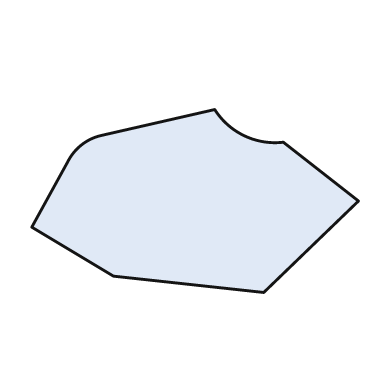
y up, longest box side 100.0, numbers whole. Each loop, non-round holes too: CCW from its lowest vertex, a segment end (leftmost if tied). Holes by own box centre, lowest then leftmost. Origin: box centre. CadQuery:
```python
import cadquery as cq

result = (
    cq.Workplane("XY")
    .moveTo(21.0, -28.0)
    .lineTo(50.0, 0.0)
    .lineTo(27.0, 18.0)
    .threePointArc((15.0, 20.0), (6.0, 28.0))
    .lineTo(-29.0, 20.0)
    .threePointArc((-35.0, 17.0), (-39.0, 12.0))
    .lineTo(-50.0, -8.0)
    .lineTo(-25.0, -23.0)
    .close()
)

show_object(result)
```